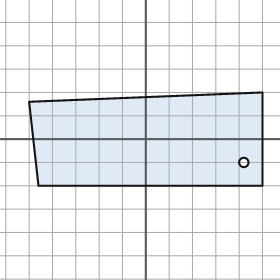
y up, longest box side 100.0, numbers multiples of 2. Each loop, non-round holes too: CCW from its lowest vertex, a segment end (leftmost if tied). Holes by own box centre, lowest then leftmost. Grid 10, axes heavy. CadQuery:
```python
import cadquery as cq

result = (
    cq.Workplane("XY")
    .moveTo(-46.0, -20.0)
    .lineTo(50.0, -20.0)
    .lineTo(50.0, 20.0)
    .lineTo(-50.0, 16.0)
    .close()
    .moveTo(42.0, -10.0)
    .circle(2.0)
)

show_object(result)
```